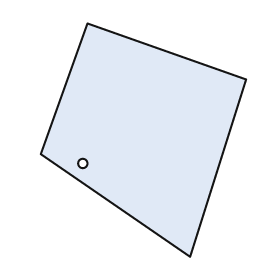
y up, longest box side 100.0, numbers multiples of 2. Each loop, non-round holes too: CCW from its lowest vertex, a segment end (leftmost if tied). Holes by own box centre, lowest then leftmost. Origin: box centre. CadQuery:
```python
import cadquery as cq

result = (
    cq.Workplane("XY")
    .moveTo(20.0, -50.0)
    .lineTo(44.0, 26.0)
    .lineTo(-24.0, 50.0)
    .lineTo(-44.0, -6.0)
    .close()
    .moveTo(-26.0, -10.0)
    .circle(2.0)
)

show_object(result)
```